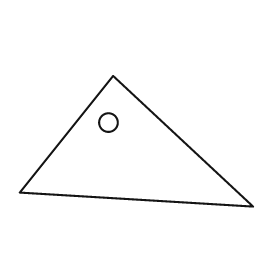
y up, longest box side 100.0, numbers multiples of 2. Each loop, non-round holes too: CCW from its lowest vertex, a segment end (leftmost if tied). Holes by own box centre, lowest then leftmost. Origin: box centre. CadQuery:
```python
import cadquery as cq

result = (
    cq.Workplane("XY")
    .moveTo(50.0, -28.0)
    .lineTo(-10.0, 28.0)
    .lineTo(-50.0, -22.0)
    .close()
    .moveTo(-12.0, 8.0)
    .circle(4.0)
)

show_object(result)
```